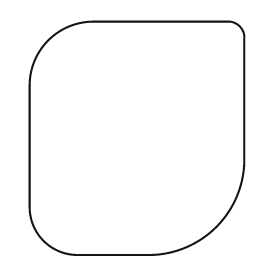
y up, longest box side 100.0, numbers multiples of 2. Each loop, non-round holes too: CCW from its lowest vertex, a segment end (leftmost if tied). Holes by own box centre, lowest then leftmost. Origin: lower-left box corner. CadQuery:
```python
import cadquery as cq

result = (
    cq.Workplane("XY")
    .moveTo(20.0, 0.0)
    .lineTo(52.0, 0.0)
    .threePointArc((80.0, 12.0), (92.0, 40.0))
    .lineTo(92.0, 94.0)
    .threePointArc((90.0, 98.0), (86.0, 100.0))
    .lineTo(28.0, 100.0)
    .threePointArc((8.0, 92.0), (0.0, 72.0))
    .lineTo(0.0, 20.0)
    .threePointArc((6.0, 6.0), (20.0, 0.0))
    .close()
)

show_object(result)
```